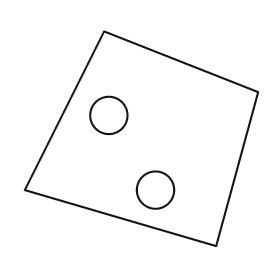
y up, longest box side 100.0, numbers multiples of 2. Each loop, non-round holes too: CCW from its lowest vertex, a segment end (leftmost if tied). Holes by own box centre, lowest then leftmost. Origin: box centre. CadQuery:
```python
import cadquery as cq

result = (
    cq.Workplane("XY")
    .moveTo(32.0, -46.0)
    .lineTo(50.0, 20.0)
    .lineTo(-16.0, 46.0)
    .lineTo(-50.0, -22.0)
    .close()
    .moveTo(6.0, -22.0)
    .circle(8.0)
    .moveTo(-14.0, 10.0)
    .circle(8.0)
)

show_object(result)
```